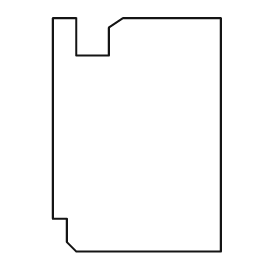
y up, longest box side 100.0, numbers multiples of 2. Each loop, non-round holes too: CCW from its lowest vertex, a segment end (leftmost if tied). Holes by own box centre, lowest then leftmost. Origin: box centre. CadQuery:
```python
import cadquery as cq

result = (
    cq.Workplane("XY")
    .moveTo(-26.0, -50.0)
    .lineTo(36.0, -50.0)
    .lineTo(36.0, 50.0)
    .lineTo(-6.0, 50.0)
    .lineTo(-12.0, 46.0)
    .lineTo(-12.0, 34.0)
    .lineTo(-26.0, 34.0)
    .lineTo(-26.0, 50.0)
    .lineTo(-36.0, 50.0)
    .lineTo(-36.0, -36.0)
    .lineTo(-30.0, -36.0)
    .lineTo(-30.0, -46.0)
    .close()
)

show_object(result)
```